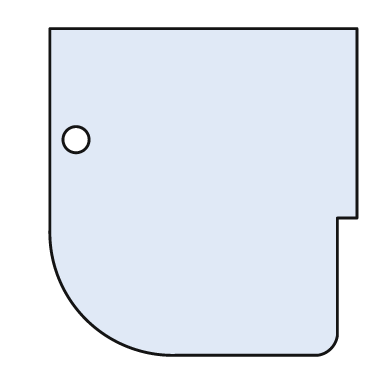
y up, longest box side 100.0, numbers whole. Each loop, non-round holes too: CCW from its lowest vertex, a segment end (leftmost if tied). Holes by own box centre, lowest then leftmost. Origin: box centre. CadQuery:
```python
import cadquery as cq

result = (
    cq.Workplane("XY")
    .moveTo(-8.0, -50.0)
    .lineTo(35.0, -50.0)
    .threePointArc((39.0, -48.0), (41.0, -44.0))
    .lineTo(41.0, -8.0)
    .lineTo(47.0, -8.0)
    .lineTo(47.0, 50.0)
    .lineTo(-47.0, 50.0)
    .lineTo(-47.0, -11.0)
    .threePointArc((-36.0, -39.0), (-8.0, -50.0))
    .close()
    .moveTo(-39.0, 16.0)
    .circle(4.0)
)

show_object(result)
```